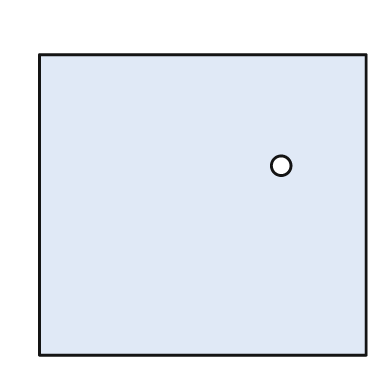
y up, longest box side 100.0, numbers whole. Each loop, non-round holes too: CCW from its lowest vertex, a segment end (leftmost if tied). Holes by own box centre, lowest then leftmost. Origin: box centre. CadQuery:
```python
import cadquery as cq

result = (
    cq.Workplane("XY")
    .moveTo(-50.0, -46.0)
    .lineTo(50.0, -46.0)
    .lineTo(50.0, 46.0)
    .lineTo(-50.0, 46.0)
    .close()
    .moveTo(24.0, 12.0)
    .circle(3.0)
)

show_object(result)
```